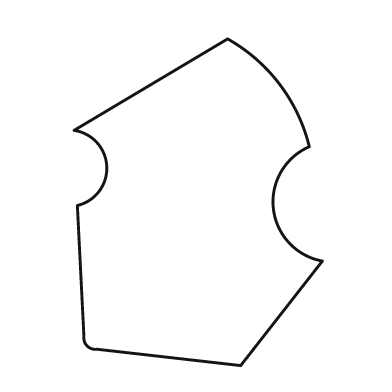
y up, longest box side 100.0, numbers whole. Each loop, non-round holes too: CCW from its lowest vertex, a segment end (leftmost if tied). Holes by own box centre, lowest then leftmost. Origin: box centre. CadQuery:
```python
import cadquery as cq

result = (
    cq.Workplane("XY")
    .moveTo(13.0, -50.0)
    .lineTo(38.0, -18.0)
    .threePointArc((23.0, -2.0), (34.0, 17.0))
    .threePointArc((25.0, 36.0), (9.0, 50.0))
    .lineTo(-38.0, 22.0)
    .threePointArc((-28.0, 11.0), (-37.0, -1.0))
    .lineTo(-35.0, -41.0)
    .threePointArc((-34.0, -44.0), (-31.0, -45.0))
    .close()
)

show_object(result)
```